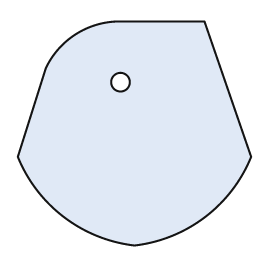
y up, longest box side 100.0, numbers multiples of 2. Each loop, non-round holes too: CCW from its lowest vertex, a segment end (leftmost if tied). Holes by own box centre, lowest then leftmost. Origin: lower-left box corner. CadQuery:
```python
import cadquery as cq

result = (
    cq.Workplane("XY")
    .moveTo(50.0, 0.0)
    .threePointArc((80.0, 12.0), (100.0, 38.0))
    .lineTo(80.0, 96.0)
    .lineTo(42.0, 96.0)
    .threePointArc((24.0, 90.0), (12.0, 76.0))
    .lineTo(0.0, 38.0)
    .threePointArc((20.0, 12.0), (50.0, 0.0))
    .close()
    .moveTo(44.0, 70.0)
    .circle(4.0)
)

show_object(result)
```